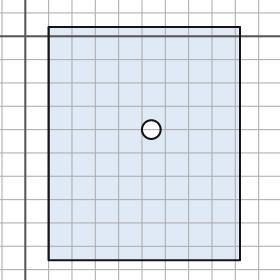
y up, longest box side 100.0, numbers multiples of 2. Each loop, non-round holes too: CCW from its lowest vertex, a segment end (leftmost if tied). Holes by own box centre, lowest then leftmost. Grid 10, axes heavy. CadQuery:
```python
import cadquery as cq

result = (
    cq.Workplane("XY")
    .moveTo(10.0, -96.0)
    .lineTo(92.0, -96.0)
    .lineTo(92.0, 4.0)
    .lineTo(10.0, 4.0)
    .close()
    .moveTo(54.0, -40.0)
    .circle(4.0)
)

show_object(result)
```